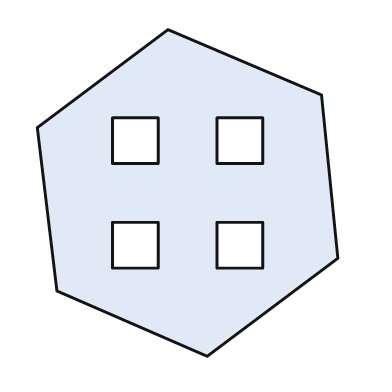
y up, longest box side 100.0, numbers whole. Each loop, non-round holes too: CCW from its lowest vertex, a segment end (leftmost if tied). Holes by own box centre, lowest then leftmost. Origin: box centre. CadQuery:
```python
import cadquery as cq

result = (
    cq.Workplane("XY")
    .moveTo(6.0, -50.0)
    .lineTo(46.0, -20.0)
    .lineTo(41.0, 30.0)
    .lineTo(-6.0, 50.0)
    .lineTo(-46.0, 20.0)
    .lineTo(-40.0, -30.0)
    .close()
    .moveTo(-23.0, -23.0)
    .lineTo(-9.0, -23.0)
    .lineTo(-9.0, -9.0)
    .lineTo(-23.0, -9.0)
    .close()
    .moveTo(9.0, -23.0)
    .lineTo(23.0, -23.0)
    .lineTo(23.0, -9.0)
    .lineTo(9.0, -9.0)
    .close()
    .moveTo(-23.0, 9.0)
    .lineTo(-9.0, 9.0)
    .lineTo(-9.0, 23.0)
    .lineTo(-23.0, 23.0)
    .close()
    .moveTo(9.0, 9.0)
    .lineTo(23.0, 9.0)
    .lineTo(23.0, 23.0)
    .lineTo(9.0, 23.0)
    .close()
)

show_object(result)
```